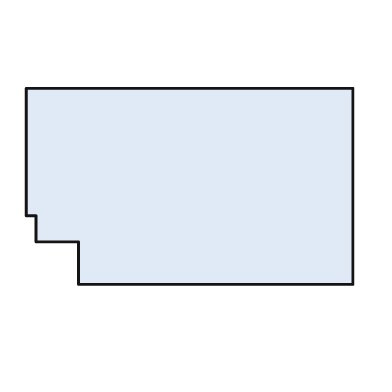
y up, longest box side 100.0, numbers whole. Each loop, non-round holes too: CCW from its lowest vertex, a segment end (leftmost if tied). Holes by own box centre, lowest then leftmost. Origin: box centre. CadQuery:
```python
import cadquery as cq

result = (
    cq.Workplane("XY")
    .moveTo(-34.0, -30.0)
    .lineTo(50.0, -30.0)
    .lineTo(50.0, 30.0)
    .lineTo(-50.0, 30.0)
    .lineTo(-50.0, -9.0)
    .lineTo(-47.0, -9.0)
    .lineTo(-47.0, -17.0)
    .lineTo(-34.0, -17.0)
    .close()
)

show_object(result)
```